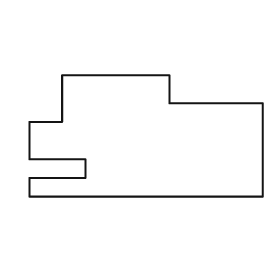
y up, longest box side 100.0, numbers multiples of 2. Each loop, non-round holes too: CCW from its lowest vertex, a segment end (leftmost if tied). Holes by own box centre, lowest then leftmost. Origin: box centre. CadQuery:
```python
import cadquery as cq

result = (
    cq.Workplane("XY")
    .moveTo(-50.0, -26.0)
    .lineTo(50.0, -26.0)
    .lineTo(50.0, 14.0)
    .lineTo(10.0, 14.0)
    .lineTo(10.0, 26.0)
    .lineTo(-36.0, 26.0)
    .lineTo(-36.0, 6.0)
    .lineTo(-50.0, 6.0)
    .lineTo(-50.0, -10.0)
    .lineTo(-26.0, -10.0)
    .lineTo(-26.0, -18.0)
    .lineTo(-50.0, -18.0)
    .close()
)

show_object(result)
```